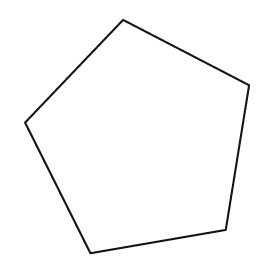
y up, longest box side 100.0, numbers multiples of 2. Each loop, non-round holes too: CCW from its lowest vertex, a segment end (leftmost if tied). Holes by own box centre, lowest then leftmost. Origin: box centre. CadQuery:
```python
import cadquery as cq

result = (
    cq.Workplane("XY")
    .moveTo(-20.0, -50.0)
    .lineTo(38.0, -40.0)
    .lineTo(48.0, 22.0)
    .lineTo(-6.0, 50.0)
    .lineTo(-48.0, 6.0)
    .close()
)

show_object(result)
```